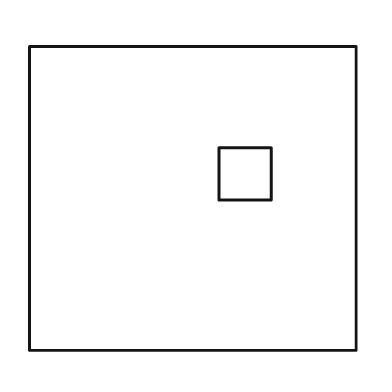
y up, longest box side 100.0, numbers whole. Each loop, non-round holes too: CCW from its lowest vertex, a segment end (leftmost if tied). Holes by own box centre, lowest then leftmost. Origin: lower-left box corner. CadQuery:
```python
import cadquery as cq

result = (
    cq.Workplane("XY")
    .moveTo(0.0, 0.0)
    .lineTo(100.0, 0.0)
    .lineTo(100.0, 93.0)
    .lineTo(0.0, 93.0)
    .close()
    .moveTo(58.0, 46.0)
    .lineTo(74.0, 46.0)
    .lineTo(74.0, 62.0)
    .lineTo(58.0, 62.0)
    .close()
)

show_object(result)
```